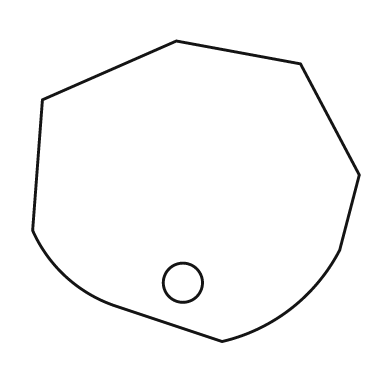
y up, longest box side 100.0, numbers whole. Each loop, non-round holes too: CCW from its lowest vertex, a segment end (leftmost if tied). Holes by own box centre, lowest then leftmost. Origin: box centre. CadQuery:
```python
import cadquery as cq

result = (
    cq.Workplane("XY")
    .moveTo(8.0, -46.0)
    .threePointArc((29.0, -36.0), (44.0, -18.0))
    .lineTo(50.0, 5.0)
    .lineTo(32.0, 39.0)
    .lineTo(-6.0, 46.0)
    .lineTo(-47.0, 28.0)
    .lineTo(-50.0, -12.0)
    .threePointArc((-40.0, -26.0), (-25.0, -35.0))
    .close()
    .moveTo(-4.0, -28.0)
    .circle(6.0)
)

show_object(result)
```